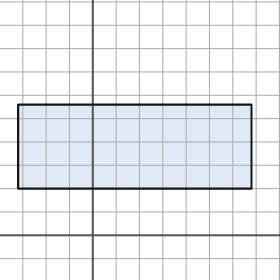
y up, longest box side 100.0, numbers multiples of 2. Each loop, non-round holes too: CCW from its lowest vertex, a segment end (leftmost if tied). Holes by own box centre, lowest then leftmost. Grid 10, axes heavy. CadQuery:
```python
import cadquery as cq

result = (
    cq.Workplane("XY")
    .moveTo(-32.0, 20.0)
    .lineTo(68.0, 20.0)
    .lineTo(68.0, 56.0)
    .lineTo(-32.0, 56.0)
    .close()
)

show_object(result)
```